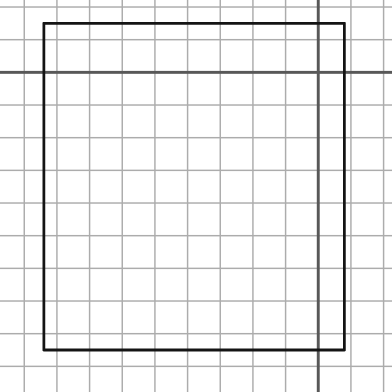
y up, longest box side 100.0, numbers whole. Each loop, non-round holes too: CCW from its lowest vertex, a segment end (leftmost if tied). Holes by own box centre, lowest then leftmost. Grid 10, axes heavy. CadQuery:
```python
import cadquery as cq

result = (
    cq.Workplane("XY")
    .moveTo(-84.0, -85.0)
    .lineTo(8.0, -85.0)
    .lineTo(8.0, 15.0)
    .lineTo(-84.0, 15.0)
    .close()
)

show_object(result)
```